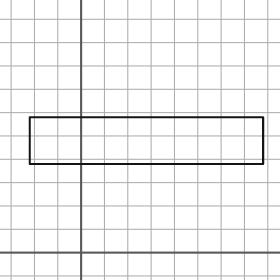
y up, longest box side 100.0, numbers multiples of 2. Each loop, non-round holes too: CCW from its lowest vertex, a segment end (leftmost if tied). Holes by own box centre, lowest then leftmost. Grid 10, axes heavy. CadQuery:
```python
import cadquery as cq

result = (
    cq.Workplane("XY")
    .moveTo(-22.0, 38.0)
    .lineTo(78.0, 38.0)
    .lineTo(78.0, 58.0)
    .lineTo(-22.0, 58.0)
    .close()
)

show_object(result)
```